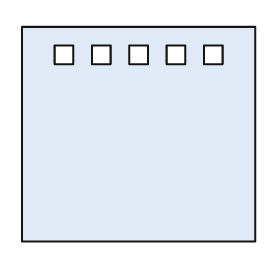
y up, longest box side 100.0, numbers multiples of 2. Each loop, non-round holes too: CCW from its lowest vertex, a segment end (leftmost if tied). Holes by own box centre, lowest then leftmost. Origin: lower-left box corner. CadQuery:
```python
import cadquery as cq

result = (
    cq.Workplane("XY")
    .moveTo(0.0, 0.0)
    .lineTo(100.0, 0.0)
    .lineTo(100.0, 92.0)
    .lineTo(0.0, 92.0)
    .close()
    .moveTo(14.0, 76.0)
    .lineTo(22.0, 76.0)
    .lineTo(22.0, 84.0)
    .lineTo(14.0, 84.0)
    .close()
    .moveTo(30.0, 76.0)
    .lineTo(38.0, 76.0)
    .lineTo(38.0, 84.0)
    .lineTo(30.0, 84.0)
    .close()
    .moveTo(46.0, 76.0)
    .lineTo(54.0, 76.0)
    .lineTo(54.0, 84.0)
    .lineTo(46.0, 84.0)
    .close()
    .moveTo(62.0, 76.0)
    .lineTo(70.0, 76.0)
    .lineTo(70.0, 84.0)
    .lineTo(62.0, 84.0)
    .close()
    .moveTo(78.0, 76.0)
    .lineTo(86.0, 76.0)
    .lineTo(86.0, 84.0)
    .lineTo(78.0, 84.0)
    .close()
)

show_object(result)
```